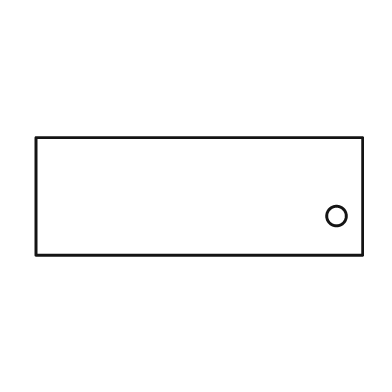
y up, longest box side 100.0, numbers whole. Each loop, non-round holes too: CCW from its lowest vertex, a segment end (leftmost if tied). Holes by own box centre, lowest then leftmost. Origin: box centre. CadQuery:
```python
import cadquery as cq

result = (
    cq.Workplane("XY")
    .moveTo(-50.0, -18.0)
    .lineTo(50.0, -18.0)
    .lineTo(50.0, 18.0)
    .lineTo(-50.0, 18.0)
    .close()
    .moveTo(42.0, -6.0)
    .circle(3.0)
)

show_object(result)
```